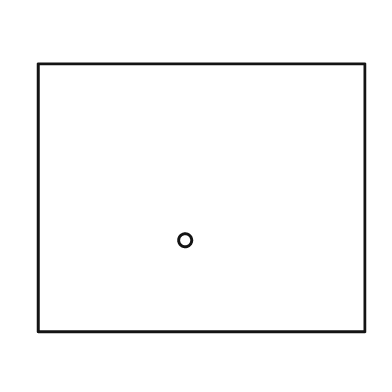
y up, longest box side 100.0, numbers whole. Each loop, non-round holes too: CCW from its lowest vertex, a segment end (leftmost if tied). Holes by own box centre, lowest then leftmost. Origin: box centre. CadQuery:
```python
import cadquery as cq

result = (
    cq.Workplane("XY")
    .moveTo(-50.0, -41.0)
    .lineTo(50.0, -41.0)
    .lineTo(50.0, 41.0)
    .lineTo(-50.0, 41.0)
    .close()
    .moveTo(-5.0, -13.0)
    .circle(2.0)
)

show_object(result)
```